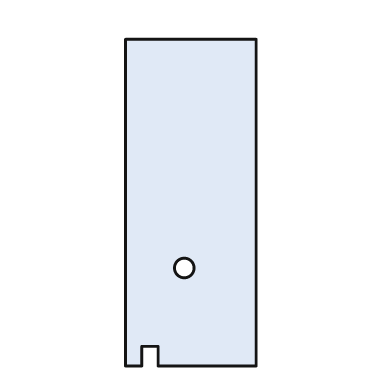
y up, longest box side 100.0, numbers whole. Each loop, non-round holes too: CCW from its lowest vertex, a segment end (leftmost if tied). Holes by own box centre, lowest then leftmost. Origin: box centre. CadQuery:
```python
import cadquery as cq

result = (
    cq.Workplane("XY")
    .moveTo(-20.0, -50.0)
    .lineTo(-15.0, -50.0)
    .lineTo(-15.0, -44.0)
    .lineTo(-10.0, -44.0)
    .lineTo(-10.0, -50.0)
    .lineTo(20.0, -50.0)
    .lineTo(20.0, 50.0)
    .lineTo(-20.0, 50.0)
    .close()
    .moveTo(-2.0, -20.0)
    .circle(3.0)
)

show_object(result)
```